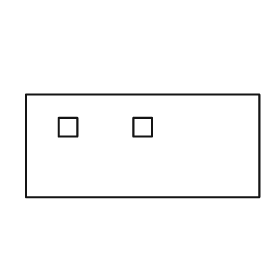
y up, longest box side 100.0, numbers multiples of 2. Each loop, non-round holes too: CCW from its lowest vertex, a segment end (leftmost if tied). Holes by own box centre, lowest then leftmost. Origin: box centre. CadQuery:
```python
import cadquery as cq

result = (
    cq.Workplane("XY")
    .moveTo(-50.0, -22.0)
    .lineTo(50.0, -22.0)
    .lineTo(50.0, 22.0)
    .lineTo(-50.0, 22.0)
    .close()
    .moveTo(-36.0, 4.0)
    .lineTo(-28.0, 4.0)
    .lineTo(-28.0, 12.0)
    .lineTo(-36.0, 12.0)
    .close()
    .moveTo(-4.0, 4.0)
    .lineTo(4.0, 4.0)
    .lineTo(4.0, 12.0)
    .lineTo(-4.0, 12.0)
    .close()
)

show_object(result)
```